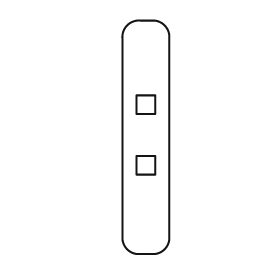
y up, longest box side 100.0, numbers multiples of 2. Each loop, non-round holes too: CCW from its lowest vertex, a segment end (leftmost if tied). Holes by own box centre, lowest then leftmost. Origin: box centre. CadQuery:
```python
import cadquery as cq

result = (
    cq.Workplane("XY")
    .moveTo(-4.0, -50.0)
    .lineTo(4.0, -50.0)
    .threePointArc((8.0, -48.0), (10.0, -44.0))
    .lineTo(10.0, 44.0)
    .threePointArc((8.0, 48.0), (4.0, 50.0))
    .lineTo(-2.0, 50.0)
    .threePointArc((-8.0, 48.0), (-10.0, 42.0))
    .lineTo(-10.0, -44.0)
    .threePointArc((-8.0, -48.0), (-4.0, -50.0))
    .close()
    .moveTo(-4.0, -16.0)
    .lineTo(4.0, -16.0)
    .lineTo(4.0, -8.0)
    .lineTo(-4.0, -8.0)
    .close()
    .moveTo(-4.0, 10.0)
    .lineTo(4.0, 10.0)
    .lineTo(4.0, 18.0)
    .lineTo(-4.0, 18.0)
    .close()
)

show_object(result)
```